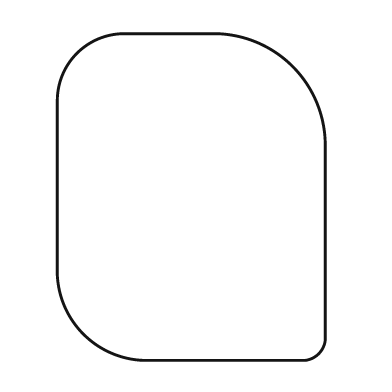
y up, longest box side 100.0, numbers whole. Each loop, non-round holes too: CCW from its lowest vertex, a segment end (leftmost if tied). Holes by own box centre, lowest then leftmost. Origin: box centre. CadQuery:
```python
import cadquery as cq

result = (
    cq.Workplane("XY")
    .moveTo(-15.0, -50.0)
    .lineTo(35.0, -50.0)
    .threePointArc((39.0, -48.0), (41.0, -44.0))
    .lineTo(41.0, 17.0)
    .threePointArc((31.0, 40.0), (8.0, 50.0))
    .lineTo(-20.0, 50.0)
    .threePointArc((-35.0, 44.0), (-41.0, 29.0))
    .lineTo(-41.0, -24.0)
    .threePointArc((-33.0, -42.0), (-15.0, -50.0))
    .close()
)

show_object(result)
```